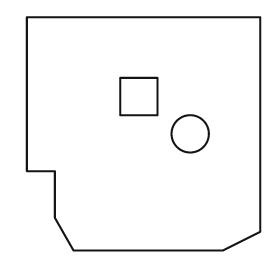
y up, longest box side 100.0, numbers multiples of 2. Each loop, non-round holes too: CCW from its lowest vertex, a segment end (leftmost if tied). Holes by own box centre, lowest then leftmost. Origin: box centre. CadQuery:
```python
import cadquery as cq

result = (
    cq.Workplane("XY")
    .moveTo(-30.0, -50.0)
    .lineTo(34.0, -50.0)
    .lineTo(50.0, -42.0)
    .lineTo(50.0, 50.0)
    .lineTo(-50.0, 50.0)
    .lineTo(-50.0, -16.0)
    .lineTo(-38.0, -16.0)
    .lineTo(-38.0, -36.0)
    .close()
    .moveTo(20.0, 0.0)
    .circle(8.0)
    .moveTo(-10.0, 8.0)
    .lineTo(6.0, 8.0)
    .lineTo(6.0, 24.0)
    .lineTo(-10.0, 24.0)
    .close()
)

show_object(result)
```